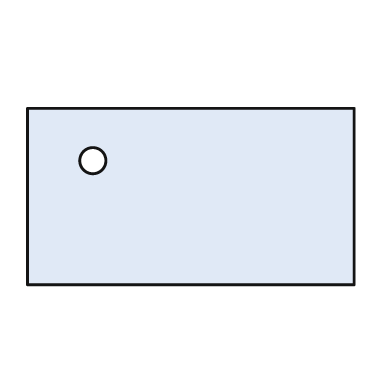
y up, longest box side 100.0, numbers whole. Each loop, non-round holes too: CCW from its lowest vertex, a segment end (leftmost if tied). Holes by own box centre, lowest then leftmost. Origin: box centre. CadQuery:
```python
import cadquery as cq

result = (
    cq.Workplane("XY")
    .moveTo(-50.0, -27.0)
    .lineTo(50.0, -27.0)
    .lineTo(50.0, 27.0)
    .lineTo(-50.0, 27.0)
    .close()
    .moveTo(-30.0, 11.0)
    .circle(4.0)
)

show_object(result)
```